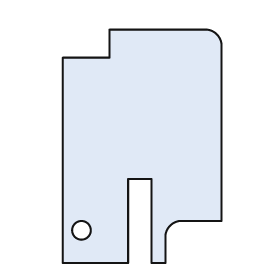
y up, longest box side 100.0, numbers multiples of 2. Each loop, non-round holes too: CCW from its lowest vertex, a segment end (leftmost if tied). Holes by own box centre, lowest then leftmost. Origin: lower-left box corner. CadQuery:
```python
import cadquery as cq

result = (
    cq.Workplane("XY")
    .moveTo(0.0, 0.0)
    .lineTo(28.0, 0.0)
    .lineTo(28.0, 36.0)
    .lineTo(38.0, 36.0)
    .lineTo(38.0, 0.0)
    .lineTo(44.0, 0.0)
    .lineTo(44.0, 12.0)
    .threePointArc((46.0, 16.0), (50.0, 18.0))
    .lineTo(68.0, 18.0)
    .lineTo(68.0, 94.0)
    .threePointArc((66.0, 98.0), (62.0, 100.0))
    .lineTo(20.0, 100.0)
    .lineTo(20.0, 88.0)
    .lineTo(0.0, 88.0)
    .close()
    .moveTo(8.0, 14.0)
    .circle(4.0)
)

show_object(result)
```